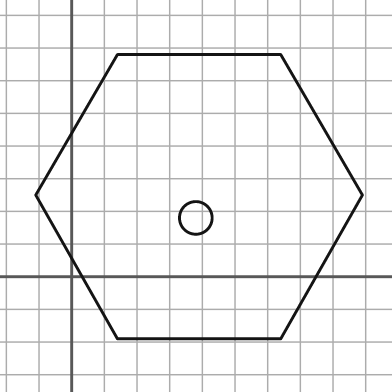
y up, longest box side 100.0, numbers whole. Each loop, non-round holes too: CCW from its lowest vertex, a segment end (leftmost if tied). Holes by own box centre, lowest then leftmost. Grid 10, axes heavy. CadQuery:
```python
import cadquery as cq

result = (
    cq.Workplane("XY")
    .moveTo(14.0, -19.0)
    .lineTo(64.0, -19.0)
    .lineTo(89.0, 25.0)
    .lineTo(64.0, 68.0)
    .lineTo(14.0, 68.0)
    .lineTo(-11.0, 25.0)
    .close()
    .moveTo(38.0, 18.0)
    .circle(5.0)
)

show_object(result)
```